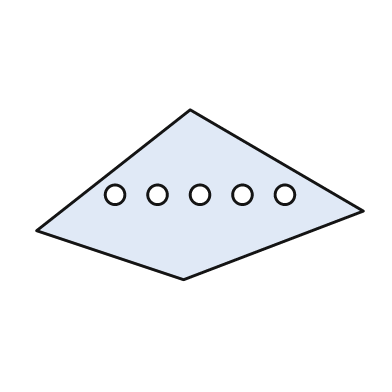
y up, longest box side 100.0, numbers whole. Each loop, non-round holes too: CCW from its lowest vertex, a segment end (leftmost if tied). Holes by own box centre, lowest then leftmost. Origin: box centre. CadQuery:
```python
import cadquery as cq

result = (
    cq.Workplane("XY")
    .moveTo(-5.0, -26.0)
    .lineTo(50.0, -5.0)
    .lineTo(-3.0, 26.0)
    .lineTo(-50.0, -11.0)
    .close()
    .moveTo(-26.0, 0.0)
    .circle(3.0)
    .moveTo(-13.0, 0.0)
    .circle(3.0)
    .moveTo(0.0, 0.0)
    .circle(3.0)
    .moveTo(13.0, 0.0)
    .circle(3.0)
    .moveTo(26.0, 0.0)
    .circle(3.0)
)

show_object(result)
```